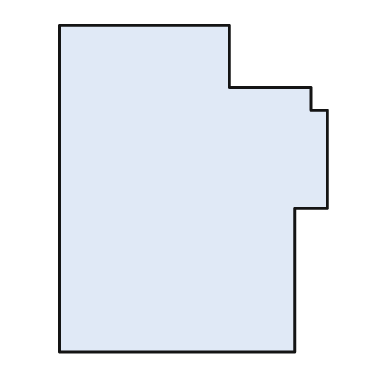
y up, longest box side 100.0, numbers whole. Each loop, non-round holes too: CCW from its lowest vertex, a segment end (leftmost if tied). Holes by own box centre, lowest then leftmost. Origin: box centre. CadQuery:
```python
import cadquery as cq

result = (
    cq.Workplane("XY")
    .moveTo(-41.0, -50.0)
    .lineTo(31.0, -50.0)
    .lineTo(31.0, -6.0)
    .lineTo(41.0, -6.0)
    .lineTo(41.0, 24.0)
    .lineTo(36.0, 24.0)
    .lineTo(36.0, 31.0)
    .lineTo(11.0, 31.0)
    .lineTo(11.0, 50.0)
    .lineTo(-41.0, 50.0)
    .close()
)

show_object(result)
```